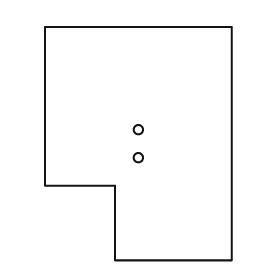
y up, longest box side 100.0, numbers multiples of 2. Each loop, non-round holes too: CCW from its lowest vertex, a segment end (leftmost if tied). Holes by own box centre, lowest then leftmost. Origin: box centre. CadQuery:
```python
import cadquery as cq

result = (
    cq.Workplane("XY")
    .moveTo(-10.0, -50.0)
    .lineTo(40.0, -50.0)
    .lineTo(40.0, 50.0)
    .lineTo(-40.0, 50.0)
    .lineTo(-40.0, -18.0)
    .lineTo(-10.0, -18.0)
    .close()
    .moveTo(0.0, -6.0)
    .circle(2.0)
    .moveTo(0.0, 6.0)
    .circle(2.0)
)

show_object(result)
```